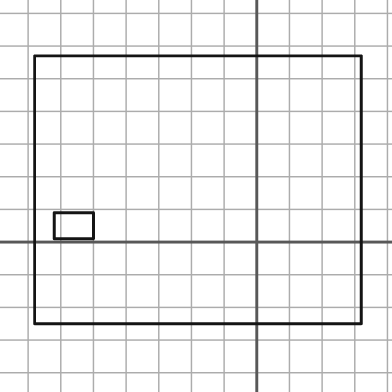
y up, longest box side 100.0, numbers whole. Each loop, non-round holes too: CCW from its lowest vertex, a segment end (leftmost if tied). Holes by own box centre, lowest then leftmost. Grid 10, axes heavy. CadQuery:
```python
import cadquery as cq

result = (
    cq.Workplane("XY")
    .moveTo(-68.0, -25.0)
    .lineTo(32.0, -25.0)
    .lineTo(32.0, 57.0)
    .lineTo(-68.0, 57.0)
    .close()
    .moveTo(-62.0, 1.0)
    .lineTo(-50.0, 1.0)
    .lineTo(-50.0, 9.0)
    .lineTo(-62.0, 9.0)
    .close()
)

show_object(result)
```